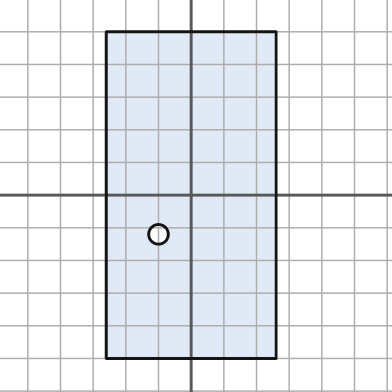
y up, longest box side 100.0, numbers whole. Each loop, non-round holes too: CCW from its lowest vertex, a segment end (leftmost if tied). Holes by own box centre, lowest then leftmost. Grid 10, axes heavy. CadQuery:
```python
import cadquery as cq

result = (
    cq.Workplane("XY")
    .moveTo(-26.0, -50.0)
    .lineTo(26.0, -50.0)
    .lineTo(26.0, 50.0)
    .lineTo(-26.0, 50.0)
    .close()
    .moveTo(-10.0, -12.0)
    .circle(3.0)
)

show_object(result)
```